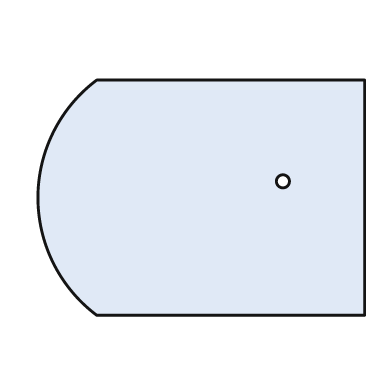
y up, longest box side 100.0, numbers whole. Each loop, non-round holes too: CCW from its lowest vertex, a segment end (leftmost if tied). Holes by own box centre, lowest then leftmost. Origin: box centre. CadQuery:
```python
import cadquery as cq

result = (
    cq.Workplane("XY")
    .moveTo(-32.0, -36.0)
    .lineTo(50.0, -36.0)
    .lineTo(50.0, 36.0)
    .lineTo(-32.0, 36.0)
    .threePointArc((-50.0, 0.0), (-32.0, -36.0))
    .close()
    .moveTo(25.0, 5.0)
    .circle(2.0)
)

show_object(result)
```